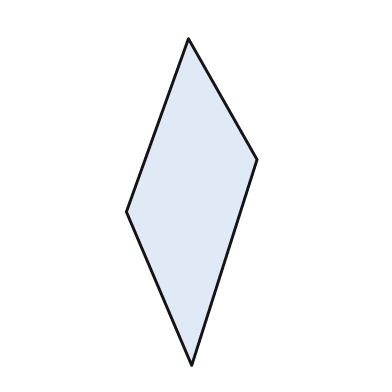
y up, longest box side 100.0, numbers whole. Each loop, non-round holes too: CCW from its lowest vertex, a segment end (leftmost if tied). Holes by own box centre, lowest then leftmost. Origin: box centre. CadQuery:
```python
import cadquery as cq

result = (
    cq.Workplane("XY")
    .moveTo(0.0, -50.0)
    .lineTo(20.0, 13.0)
    .lineTo(-1.0, 50.0)
    .lineTo(-20.0, -3.0)
    .close()
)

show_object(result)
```